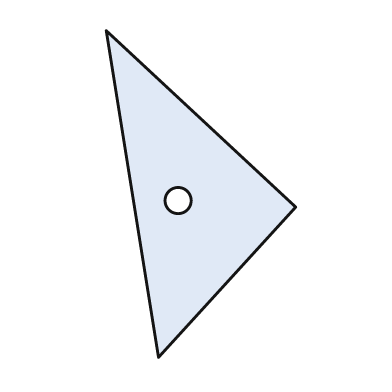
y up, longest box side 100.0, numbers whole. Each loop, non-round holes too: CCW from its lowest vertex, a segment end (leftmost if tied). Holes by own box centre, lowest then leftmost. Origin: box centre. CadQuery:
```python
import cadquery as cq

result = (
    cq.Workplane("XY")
    .moveTo(-13.0, -50.0)
    .lineTo(29.0, -4.0)
    .lineTo(-29.0, 50.0)
    .close()
    .moveTo(-7.0, -2.0)
    .circle(4.0)
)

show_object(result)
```